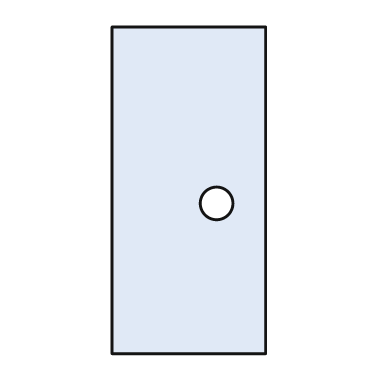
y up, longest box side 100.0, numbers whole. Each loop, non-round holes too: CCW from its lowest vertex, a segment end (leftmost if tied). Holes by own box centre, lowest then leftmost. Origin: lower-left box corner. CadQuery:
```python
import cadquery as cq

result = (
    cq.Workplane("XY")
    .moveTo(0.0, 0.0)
    .lineTo(47.0, 0.0)
    .lineTo(47.0, 100.0)
    .lineTo(0.0, 100.0)
    .close()
    .moveTo(32.0, 46.0)
    .circle(5.0)
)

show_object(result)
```